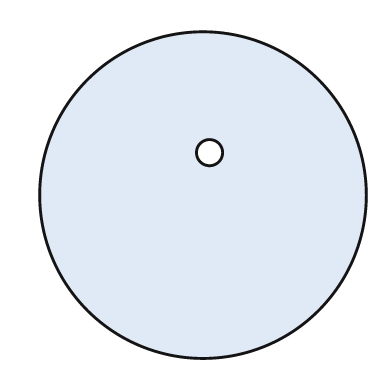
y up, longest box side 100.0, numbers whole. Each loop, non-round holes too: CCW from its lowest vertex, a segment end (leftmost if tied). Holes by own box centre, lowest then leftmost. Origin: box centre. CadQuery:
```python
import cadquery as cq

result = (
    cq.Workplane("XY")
    .moveTo(0.0, 0.0)
    .circle(50.0)
    .moveTo(2.0, 13.0)
    .circle(4.0)
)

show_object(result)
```